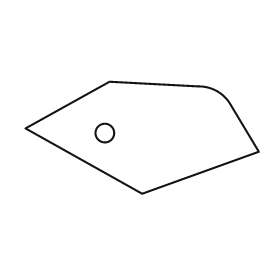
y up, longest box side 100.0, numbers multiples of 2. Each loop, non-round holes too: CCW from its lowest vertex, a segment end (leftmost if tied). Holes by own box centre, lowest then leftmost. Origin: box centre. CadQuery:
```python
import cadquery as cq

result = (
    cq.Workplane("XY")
    .moveTo(0.0, -24.0)
    .lineTo(50.0, -6.0)
    .lineTo(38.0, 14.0)
    .threePointArc((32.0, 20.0), (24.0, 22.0))
    .lineTo(-14.0, 24.0)
    .lineTo(-50.0, 4.0)
    .close()
    .moveTo(-16.0, 2.0)
    .circle(4.0)
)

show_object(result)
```